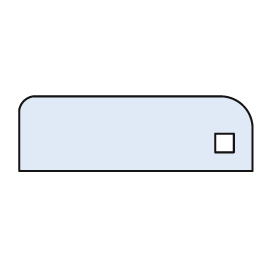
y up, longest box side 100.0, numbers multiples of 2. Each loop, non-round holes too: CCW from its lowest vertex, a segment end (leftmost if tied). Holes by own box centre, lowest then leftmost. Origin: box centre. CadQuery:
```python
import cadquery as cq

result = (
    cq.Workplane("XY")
    .moveTo(-50.0, -16.0)
    .lineTo(50.0, -16.0)
    .lineTo(50.0, 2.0)
    .threePointArc((46.0, 12.0), (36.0, 16.0))
    .lineTo(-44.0, 16.0)
    .threePointArc((-48.0, 14.0), (-50.0, 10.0))
    .close()
    .moveTo(34.0, -8.0)
    .lineTo(42.0, -8.0)
    .lineTo(42.0, 0.0)
    .lineTo(34.0, 0.0)
    .close()
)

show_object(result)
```